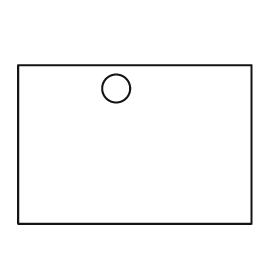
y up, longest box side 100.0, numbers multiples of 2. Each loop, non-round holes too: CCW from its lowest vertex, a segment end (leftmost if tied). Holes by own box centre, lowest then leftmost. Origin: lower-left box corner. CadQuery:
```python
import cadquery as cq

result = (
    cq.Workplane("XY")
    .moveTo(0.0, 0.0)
    .lineTo(100.0, 0.0)
    .lineTo(100.0, 68.0)
    .lineTo(0.0, 68.0)
    .close()
    .moveTo(42.0, 58.0)
    .circle(6.0)
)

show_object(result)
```